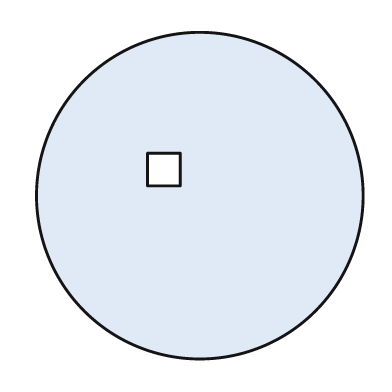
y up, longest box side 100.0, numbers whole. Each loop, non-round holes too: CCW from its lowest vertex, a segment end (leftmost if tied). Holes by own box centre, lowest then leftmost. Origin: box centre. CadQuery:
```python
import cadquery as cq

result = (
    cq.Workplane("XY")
    .moveTo(0.0, 0.0)
    .circle(50.0)
    .moveTo(-16.0, 3.0)
    .lineTo(-6.0, 3.0)
    .lineTo(-6.0, 13.0)
    .lineTo(-16.0, 13.0)
    .close()
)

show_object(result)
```